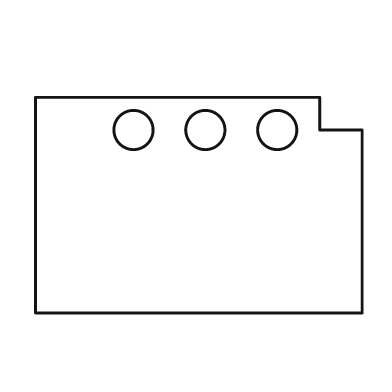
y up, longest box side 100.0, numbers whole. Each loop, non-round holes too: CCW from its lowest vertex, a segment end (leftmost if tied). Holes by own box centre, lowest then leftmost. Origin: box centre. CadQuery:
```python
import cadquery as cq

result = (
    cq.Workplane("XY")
    .moveTo(-50.0, -33.0)
    .lineTo(50.0, -33.0)
    .lineTo(50.0, 23.0)
    .lineTo(37.0, 23.0)
    .lineTo(37.0, 33.0)
    .lineTo(-50.0, 33.0)
    .close()
    .moveTo(-20.0, 23.0)
    .circle(6.0)
    .moveTo(2.0, 23.0)
    .circle(6.0)
    .moveTo(24.0, 23.0)
    .circle(6.0)
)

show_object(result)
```